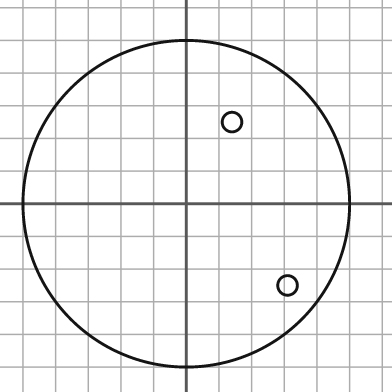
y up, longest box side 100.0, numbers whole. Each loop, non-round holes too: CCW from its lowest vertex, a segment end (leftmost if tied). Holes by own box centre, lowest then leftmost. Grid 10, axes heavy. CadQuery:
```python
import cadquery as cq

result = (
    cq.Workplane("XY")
    .moveTo(0.0, 0.0)
    .circle(50.0)
    .moveTo(31.0, -25.0)
    .circle(3.0)
    .moveTo(14.0, 25.0)
    .circle(3.0)
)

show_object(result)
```